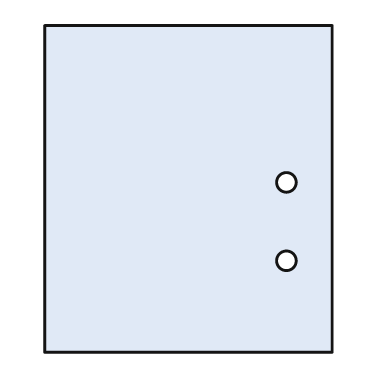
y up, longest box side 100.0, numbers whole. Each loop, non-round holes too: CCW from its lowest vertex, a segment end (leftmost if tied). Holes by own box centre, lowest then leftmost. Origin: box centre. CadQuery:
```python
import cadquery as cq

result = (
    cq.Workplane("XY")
    .moveTo(-44.0, -50.0)
    .lineTo(44.0, -50.0)
    .lineTo(44.0, 50.0)
    .lineTo(-44.0, 50.0)
    .close()
    .moveTo(30.0, -22.0)
    .circle(3.0)
    .moveTo(30.0, 2.0)
    .circle(3.0)
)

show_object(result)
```